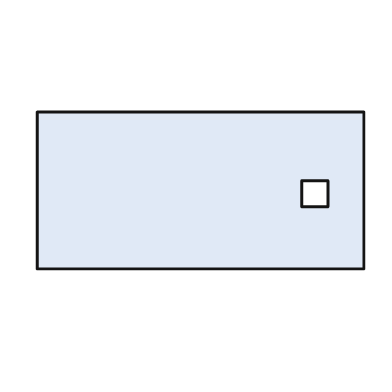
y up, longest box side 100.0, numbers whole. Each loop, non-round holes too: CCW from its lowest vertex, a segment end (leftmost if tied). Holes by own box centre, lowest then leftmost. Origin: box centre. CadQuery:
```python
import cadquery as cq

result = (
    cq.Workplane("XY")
    .moveTo(-50.0, -24.0)
    .lineTo(50.0, -24.0)
    .lineTo(50.0, 24.0)
    .lineTo(-50.0, 24.0)
    .close()
    .moveTo(31.0, -5.0)
    .lineTo(39.0, -5.0)
    .lineTo(39.0, 3.0)
    .lineTo(31.0, 3.0)
    .close()
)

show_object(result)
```